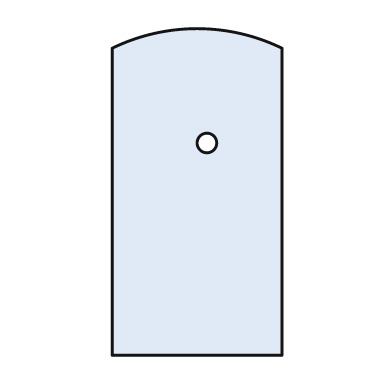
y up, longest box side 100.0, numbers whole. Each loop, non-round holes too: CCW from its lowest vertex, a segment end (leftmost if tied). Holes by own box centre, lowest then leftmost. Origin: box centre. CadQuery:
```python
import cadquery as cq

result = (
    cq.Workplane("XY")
    .moveTo(-26.0, -50.0)
    .lineTo(26.0, -50.0)
    .lineTo(26.0, 44.0)
    .threePointArc((0.0, 50.0), (-26.0, 44.0))
    .close()
    .moveTo(3.0, 15.0)
    .circle(3.0)
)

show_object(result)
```